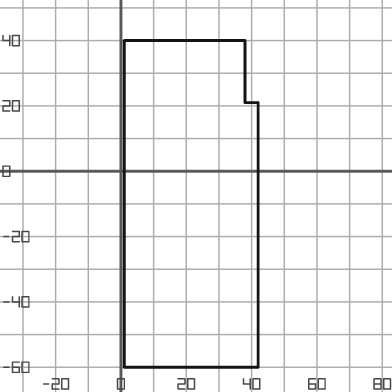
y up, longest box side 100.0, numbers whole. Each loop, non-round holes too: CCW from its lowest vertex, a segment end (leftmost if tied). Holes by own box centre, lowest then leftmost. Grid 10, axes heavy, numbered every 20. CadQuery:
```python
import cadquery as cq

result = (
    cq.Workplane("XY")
    .moveTo(1.0, -60.0)
    .lineTo(42.0, -60.0)
    .lineTo(42.0, 21.0)
    .lineTo(38.0, 21.0)
    .lineTo(38.0, 40.0)
    .lineTo(1.0, 40.0)
    .close()
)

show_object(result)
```